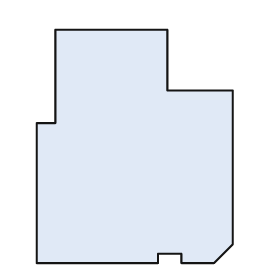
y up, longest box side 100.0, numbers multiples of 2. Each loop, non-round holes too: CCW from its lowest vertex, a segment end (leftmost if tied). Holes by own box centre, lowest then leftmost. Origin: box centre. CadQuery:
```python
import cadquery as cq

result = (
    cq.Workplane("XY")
    .moveTo(-42.0, -50.0)
    .lineTo(10.0, -50.0)
    .lineTo(10.0, -46.0)
    .lineTo(20.0, -46.0)
    .lineTo(20.0, -50.0)
    .lineTo(34.0, -50.0)
    .lineTo(42.0, -42.0)
    .lineTo(42.0, 24.0)
    .lineTo(14.0, 24.0)
    .lineTo(14.0, 50.0)
    .lineTo(-34.0, 50.0)
    .lineTo(-34.0, 10.0)
    .lineTo(-42.0, 10.0)
    .close()
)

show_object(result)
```